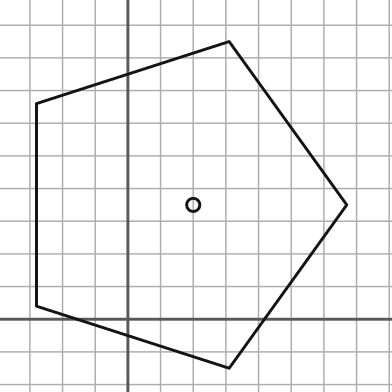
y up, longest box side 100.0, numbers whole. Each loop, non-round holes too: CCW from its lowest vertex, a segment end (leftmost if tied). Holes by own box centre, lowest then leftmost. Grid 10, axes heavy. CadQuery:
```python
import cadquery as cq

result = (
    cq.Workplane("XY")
    .moveTo(31.0, -15.0)
    .lineTo(67.0, 35.0)
    .lineTo(31.0, 85.0)
    .lineTo(-28.0, 66.0)
    .lineTo(-28.0, 4.0)
    .close()
    .moveTo(20.0, 35.0)
    .circle(2.0)
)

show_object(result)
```